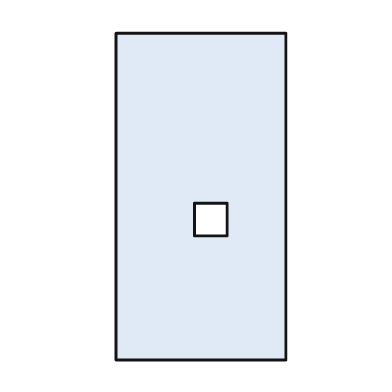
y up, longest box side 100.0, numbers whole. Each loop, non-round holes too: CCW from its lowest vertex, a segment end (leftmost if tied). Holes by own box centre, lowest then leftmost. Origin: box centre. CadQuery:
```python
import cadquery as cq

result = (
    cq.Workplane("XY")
    .moveTo(-26.0, -50.0)
    .lineTo(26.0, -50.0)
    .lineTo(26.0, 50.0)
    .lineTo(-26.0, 50.0)
    .close()
    .moveTo(-2.0, -12.0)
    .lineTo(8.0, -12.0)
    .lineTo(8.0, -2.0)
    .lineTo(-2.0, -2.0)
    .close()
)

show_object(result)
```